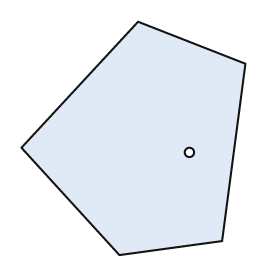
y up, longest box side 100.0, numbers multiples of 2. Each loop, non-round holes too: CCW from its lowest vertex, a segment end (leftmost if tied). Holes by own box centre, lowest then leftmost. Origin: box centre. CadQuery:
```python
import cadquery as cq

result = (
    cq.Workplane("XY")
    .moveTo(-6.0, -50.0)
    .lineTo(38.0, -44.0)
    .lineTo(48.0, 32.0)
    .lineTo(2.0, 50.0)
    .lineTo(-48.0, -4.0)
    .close()
    .moveTo(24.0, -6.0)
    .circle(2.0)
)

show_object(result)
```